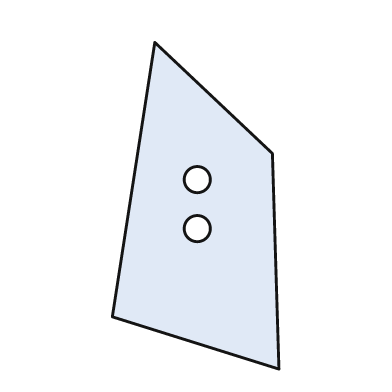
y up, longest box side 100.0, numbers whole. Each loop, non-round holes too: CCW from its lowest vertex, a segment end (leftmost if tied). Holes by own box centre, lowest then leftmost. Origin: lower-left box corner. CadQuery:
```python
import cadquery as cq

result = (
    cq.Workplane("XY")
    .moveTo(51.0, 0.0)
    .lineTo(49.0, 66.0)
    .lineTo(13.0, 100.0)
    .lineTo(0.0, 16.0)
    .close()
    .moveTo(26.0, 43.0)
    .circle(4.0)
    .moveTo(26.0, 58.0)
    .circle(4.0)
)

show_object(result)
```